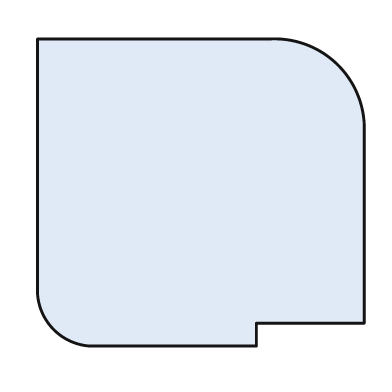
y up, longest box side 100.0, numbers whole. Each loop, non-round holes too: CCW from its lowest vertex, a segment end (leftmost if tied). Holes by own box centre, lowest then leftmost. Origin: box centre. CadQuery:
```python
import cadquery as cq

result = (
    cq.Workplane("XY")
    .moveTo(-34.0, -47.0)
    .lineTo(17.0, -47.0)
    .lineTo(17.0, -40.0)
    .lineTo(50.0, -40.0)
    .lineTo(50.0, 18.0)
    .threePointArc((42.0, 39.0), (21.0, 47.0))
    .lineTo(-50.0, 47.0)
    .lineTo(-50.0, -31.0)
    .threePointArc((-45.0, -42.0), (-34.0, -47.0))
    .close()
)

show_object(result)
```